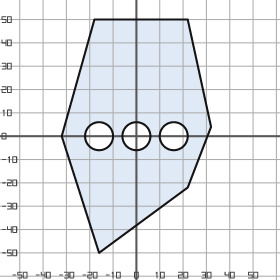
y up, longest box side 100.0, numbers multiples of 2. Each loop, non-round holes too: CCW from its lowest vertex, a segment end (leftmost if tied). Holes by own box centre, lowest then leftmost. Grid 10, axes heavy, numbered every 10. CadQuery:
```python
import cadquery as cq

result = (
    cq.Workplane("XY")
    .moveTo(-16.0, -50.0)
    .lineTo(22.0, -22.0)
    .lineTo(32.0, 4.0)
    .lineTo(22.0, 50.0)
    .lineTo(-18.0, 50.0)
    .lineTo(-32.0, 0.0)
    .close()
    .moveTo(-16.0, 0.0)
    .circle(6.0)
    .moveTo(0.0, 0.0)
    .circle(6.0)
    .moveTo(16.0, 0.0)
    .circle(6.0)
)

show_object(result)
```